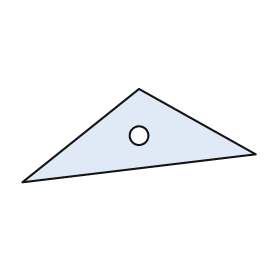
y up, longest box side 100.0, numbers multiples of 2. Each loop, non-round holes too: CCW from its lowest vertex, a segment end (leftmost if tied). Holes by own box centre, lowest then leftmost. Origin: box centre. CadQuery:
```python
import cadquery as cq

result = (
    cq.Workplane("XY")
    .moveTo(-50.0, -20.0)
    .lineTo(50.0, -8.0)
    .lineTo(0.0, 20.0)
    .close()
    .moveTo(0.0, 0.0)
    .circle(4.0)
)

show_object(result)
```